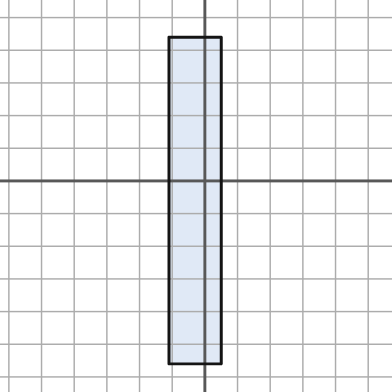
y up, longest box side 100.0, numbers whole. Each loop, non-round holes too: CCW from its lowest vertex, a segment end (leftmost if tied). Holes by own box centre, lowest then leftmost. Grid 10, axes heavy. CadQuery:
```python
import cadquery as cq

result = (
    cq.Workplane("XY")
    .moveTo(-11.0, -56.0)
    .lineTo(5.0, -56.0)
    .lineTo(5.0, 44.0)
    .lineTo(-11.0, 44.0)
    .close()
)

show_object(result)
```